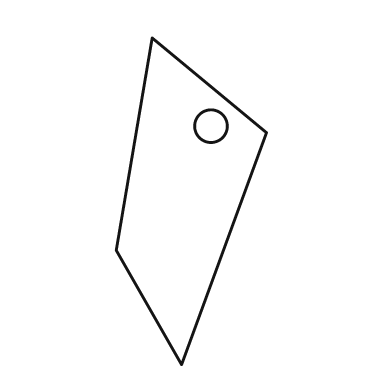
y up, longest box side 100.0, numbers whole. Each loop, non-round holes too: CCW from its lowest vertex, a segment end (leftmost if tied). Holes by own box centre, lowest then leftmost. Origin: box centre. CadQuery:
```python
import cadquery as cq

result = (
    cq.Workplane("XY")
    .moveTo(-3.0, -50.0)
    .lineTo(23.0, 21.0)
    .lineTo(-12.0, 50.0)
    .lineTo(-23.0, -15.0)
    .close()
    .moveTo(6.0, 23.0)
    .circle(5.0)
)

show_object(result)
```